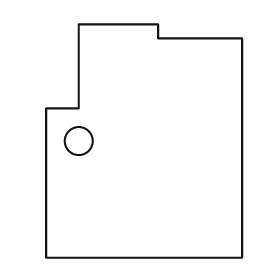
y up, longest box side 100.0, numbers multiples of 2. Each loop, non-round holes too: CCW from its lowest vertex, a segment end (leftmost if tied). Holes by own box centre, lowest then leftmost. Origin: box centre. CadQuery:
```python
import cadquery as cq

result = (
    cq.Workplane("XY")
    .moveTo(-42.0, -50.0)
    .lineTo(42.0, -50.0)
    .lineTo(42.0, 44.0)
    .lineTo(6.0, 44.0)
    .lineTo(6.0, 50.0)
    .lineTo(-28.0, 50.0)
    .lineTo(-28.0, 14.0)
    .lineTo(-42.0, 14.0)
    .close()
    .moveTo(-28.0, 0.0)
    .circle(6.0)
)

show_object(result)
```